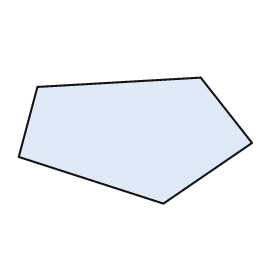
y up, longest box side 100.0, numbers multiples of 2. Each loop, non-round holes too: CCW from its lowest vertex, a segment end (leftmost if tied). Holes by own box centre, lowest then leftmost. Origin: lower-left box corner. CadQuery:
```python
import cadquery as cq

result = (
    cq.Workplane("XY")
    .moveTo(62.0, 0.0)
    .lineTo(100.0, 26.0)
    .lineTo(78.0, 54.0)
    .lineTo(8.0, 50.0)
    .lineTo(0.0, 20.0)
    .close()
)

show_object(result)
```